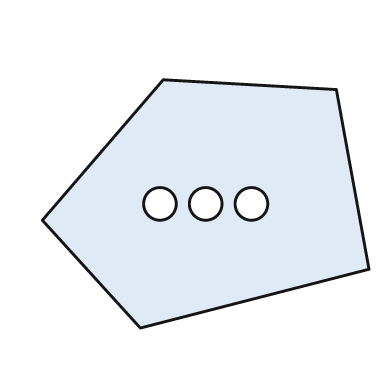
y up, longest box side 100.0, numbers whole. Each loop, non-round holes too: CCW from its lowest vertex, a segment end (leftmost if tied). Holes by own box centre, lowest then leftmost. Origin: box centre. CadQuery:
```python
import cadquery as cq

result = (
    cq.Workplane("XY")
    .moveTo(-20.0, -38.0)
    .lineTo(50.0, -20.0)
    .lineTo(40.0, 35.0)
    .lineTo(-13.0, 38.0)
    .lineTo(-50.0, -5.0)
    .close()
    .moveTo(-14.0, 0.0)
    .circle(5.0)
    .moveTo(0.0, 0.0)
    .circle(5.0)
    .moveTo(14.0, 0.0)
    .circle(5.0)
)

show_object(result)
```